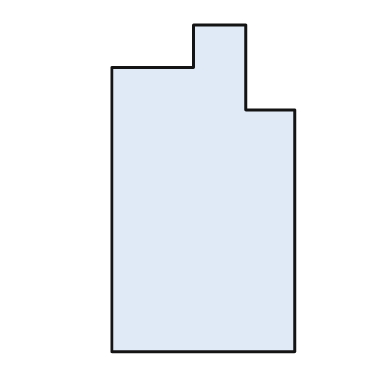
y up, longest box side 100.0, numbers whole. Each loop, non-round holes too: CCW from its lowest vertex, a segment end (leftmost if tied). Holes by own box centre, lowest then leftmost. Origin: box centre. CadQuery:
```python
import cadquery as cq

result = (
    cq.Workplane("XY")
    .moveTo(-28.0, -50.0)
    .lineTo(28.0, -50.0)
    .lineTo(28.0, 24.0)
    .lineTo(13.0, 24.0)
    .lineTo(13.0, 50.0)
    .lineTo(-3.0, 50.0)
    .lineTo(-3.0, 37.0)
    .lineTo(-28.0, 37.0)
    .close()
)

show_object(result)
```